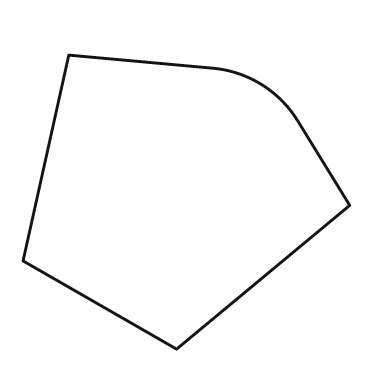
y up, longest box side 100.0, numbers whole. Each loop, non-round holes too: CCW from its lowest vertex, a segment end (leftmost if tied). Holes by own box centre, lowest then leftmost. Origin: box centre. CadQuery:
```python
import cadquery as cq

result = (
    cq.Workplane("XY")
    .moveTo(-3.0, -45.0)
    .lineTo(50.0, -1.0)
    .lineTo(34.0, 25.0)
    .threePointArc((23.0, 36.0), (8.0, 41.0))
    .lineTo(-36.0, 45.0)
    .lineTo(-50.0, -18.0)
    .close()
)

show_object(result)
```